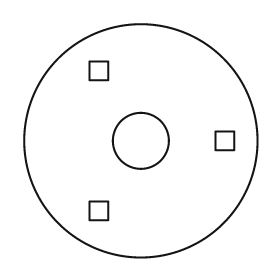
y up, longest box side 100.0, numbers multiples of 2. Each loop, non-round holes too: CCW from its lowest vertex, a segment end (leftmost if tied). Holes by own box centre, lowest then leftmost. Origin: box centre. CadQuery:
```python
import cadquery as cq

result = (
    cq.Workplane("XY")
    .moveTo(0.0, 0.0)
    .circle(50.0)
    .moveTo(-22.0, -34.0)
    .lineTo(-14.0, -34.0)
    .lineTo(-14.0, -26.0)
    .lineTo(-22.0, -26.0)
    .close()
    .moveTo(0.0, 0.0)
    .circle(12.0)
    .moveTo(32.0, -4.0)
    .lineTo(40.0, -4.0)
    .lineTo(40.0, 4.0)
    .lineTo(32.0, 4.0)
    .close()
    .moveTo(-22.0, 26.0)
    .lineTo(-14.0, 26.0)
    .lineTo(-14.0, 34.0)
    .lineTo(-22.0, 34.0)
    .close()
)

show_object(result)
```